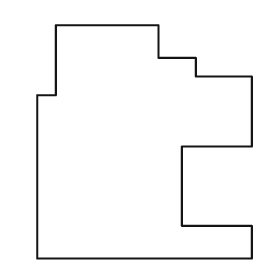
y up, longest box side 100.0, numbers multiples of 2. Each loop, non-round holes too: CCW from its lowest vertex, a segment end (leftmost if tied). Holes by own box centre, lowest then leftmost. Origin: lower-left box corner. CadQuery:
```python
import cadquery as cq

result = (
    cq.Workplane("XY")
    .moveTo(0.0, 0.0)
    .lineTo(92.0, 0.0)
    .lineTo(92.0, 14.0)
    .lineTo(62.0, 14.0)
    .lineTo(62.0, 48.0)
    .lineTo(92.0, 48.0)
    .lineTo(92.0, 78.0)
    .lineTo(68.0, 78.0)
    .lineTo(68.0, 86.0)
    .lineTo(52.0, 86.0)
    .lineTo(52.0, 100.0)
    .lineTo(8.0, 100.0)
    .lineTo(8.0, 70.0)
    .lineTo(0.0, 70.0)
    .close()
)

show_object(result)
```